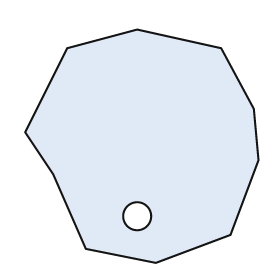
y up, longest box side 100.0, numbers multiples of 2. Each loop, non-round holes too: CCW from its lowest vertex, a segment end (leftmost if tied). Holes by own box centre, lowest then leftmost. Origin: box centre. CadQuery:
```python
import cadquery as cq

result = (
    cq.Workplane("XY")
    .moveTo(6.0, -50.0)
    .lineTo(38.0, -38.0)
    .lineTo(50.0, -6.0)
    .lineTo(48.0, 16.0)
    .lineTo(34.0, 42.0)
    .lineTo(-2.0, 50.0)
    .lineTo(-32.0, 42.0)
    .lineTo(-50.0, 6.0)
    .lineTo(-38.0, -12.0)
    .lineTo(-24.0, -44.0)
    .close()
    .moveTo(-2.0, -30.0)
    .circle(6.0)
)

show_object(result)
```